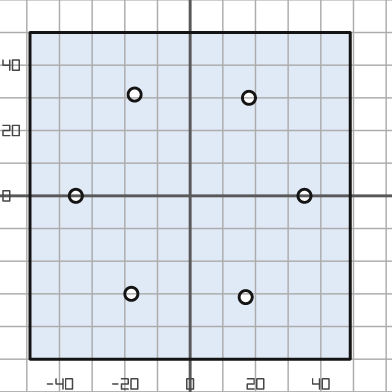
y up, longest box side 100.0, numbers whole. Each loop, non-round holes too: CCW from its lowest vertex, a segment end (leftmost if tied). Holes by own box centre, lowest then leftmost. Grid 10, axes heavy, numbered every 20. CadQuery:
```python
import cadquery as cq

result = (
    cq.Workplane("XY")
    .moveTo(-49.0, -50.0)
    .lineTo(49.0, -50.0)
    .lineTo(49.0, 50.0)
    .lineTo(-49.0, 50.0)
    .close()
    .moveTo(17.0, -31.0)
    .circle(2.0)
    .moveTo(-18.0, -30.0)
    .circle(2.0)
    .moveTo(-35.0, 0.0)
    .circle(2.0)
    .moveTo(35.0, 0.0)
    .circle(2.0)
    .moveTo(18.0, 30.0)
    .circle(2.0)
    .moveTo(-17.0, 31.0)
    .circle(2.0)
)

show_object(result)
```